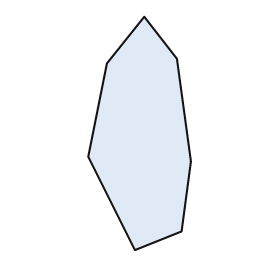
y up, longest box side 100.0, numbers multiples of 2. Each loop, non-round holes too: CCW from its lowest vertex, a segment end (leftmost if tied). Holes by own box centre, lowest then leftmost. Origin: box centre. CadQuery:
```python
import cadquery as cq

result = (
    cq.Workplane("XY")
    .moveTo(-2.0, -50.0)
    .lineTo(18.0, -42.0)
    .lineTo(22.0, -12.0)
    .lineTo(16.0, 32.0)
    .lineTo(2.0, 50.0)
    .lineTo(-14.0, 30.0)
    .lineTo(-22.0, -10.0)
    .close()
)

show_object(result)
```